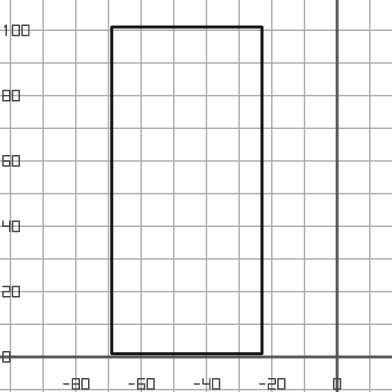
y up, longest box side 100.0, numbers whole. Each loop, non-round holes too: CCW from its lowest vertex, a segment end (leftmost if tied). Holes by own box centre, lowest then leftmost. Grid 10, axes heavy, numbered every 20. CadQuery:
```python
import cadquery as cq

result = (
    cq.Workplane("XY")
    .moveTo(-69.0, 1.0)
    .lineTo(-23.0, 1.0)
    .lineTo(-23.0, 101.0)
    .lineTo(-69.0, 101.0)
    .close()
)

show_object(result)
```